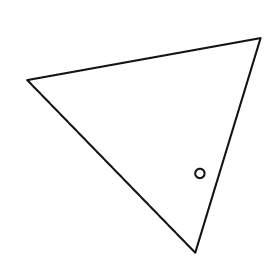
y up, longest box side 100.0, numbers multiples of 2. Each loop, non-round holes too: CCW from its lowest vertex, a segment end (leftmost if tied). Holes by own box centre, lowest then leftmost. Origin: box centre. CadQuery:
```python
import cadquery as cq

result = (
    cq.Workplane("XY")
    .moveTo(22.0, -46.0)
    .lineTo(50.0, 46.0)
    .lineTo(-50.0, 28.0)
    .close()
    .moveTo(24.0, -12.0)
    .circle(2.0)
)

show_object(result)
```